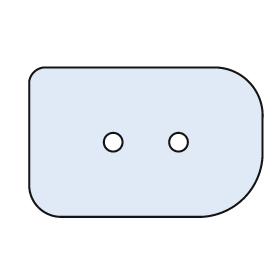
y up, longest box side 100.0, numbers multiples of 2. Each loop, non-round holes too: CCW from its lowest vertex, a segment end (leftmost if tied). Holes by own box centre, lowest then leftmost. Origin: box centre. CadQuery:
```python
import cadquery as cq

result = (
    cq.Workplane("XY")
    .moveTo(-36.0, -32.0)
    .lineTo(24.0, -32.0)
    .threePointArc((42.0, -24.0), (50.0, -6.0))
    .lineTo(50.0, 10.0)
    .threePointArc((44.0, 26.0), (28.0, 32.0))
    .lineTo(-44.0, 32.0)
    .threePointArc((-48.0, 30.0), (-50.0, 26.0))
    .lineTo(-50.0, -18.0)
    .threePointArc((-46.0, -28.0), (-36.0, -32.0))
    .close()
    .moveTo(-14.0, 0.0)
    .circle(4.0)
    .moveTo(14.0, 0.0)
    .circle(4.0)
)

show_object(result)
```